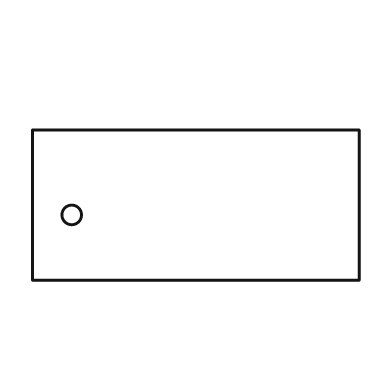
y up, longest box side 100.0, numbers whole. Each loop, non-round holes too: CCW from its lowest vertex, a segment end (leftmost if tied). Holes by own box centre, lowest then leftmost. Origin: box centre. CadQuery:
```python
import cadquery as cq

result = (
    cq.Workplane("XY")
    .moveTo(-50.0, -23.0)
    .lineTo(50.0, -23.0)
    .lineTo(50.0, 23.0)
    .lineTo(-50.0, 23.0)
    .close()
    .moveTo(-38.0, -3.0)
    .circle(3.0)
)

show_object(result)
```